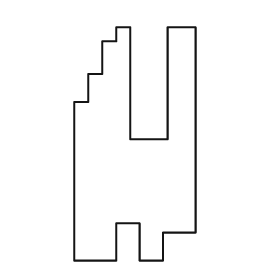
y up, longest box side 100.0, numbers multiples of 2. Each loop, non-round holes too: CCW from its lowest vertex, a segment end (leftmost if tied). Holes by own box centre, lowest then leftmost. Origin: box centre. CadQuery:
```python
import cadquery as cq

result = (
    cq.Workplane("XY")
    .moveTo(-26.0, -50.0)
    .lineTo(-8.0, -50.0)
    .lineTo(-8.0, -34.0)
    .lineTo(2.0, -34.0)
    .lineTo(2.0, -50.0)
    .lineTo(12.0, -50.0)
    .lineTo(12.0, -38.0)
    .lineTo(26.0, -38.0)
    .lineTo(26.0, 50.0)
    .lineTo(14.0, 50.0)
    .lineTo(14.0, 2.0)
    .lineTo(-2.0, 2.0)
    .lineTo(-2.0, 50.0)
    .lineTo(-8.0, 50.0)
    .lineTo(-8.0, 44.0)
    .lineTo(-14.0, 44.0)
    .lineTo(-14.0, 30.0)
    .lineTo(-20.0, 30.0)
    .lineTo(-20.0, 18.0)
    .lineTo(-26.0, 18.0)
    .close()
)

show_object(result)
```